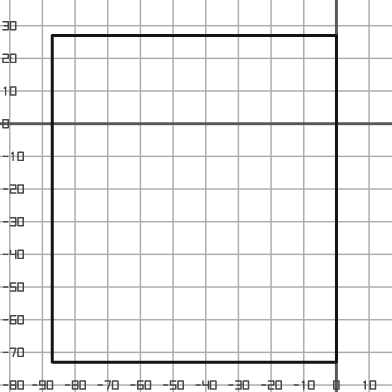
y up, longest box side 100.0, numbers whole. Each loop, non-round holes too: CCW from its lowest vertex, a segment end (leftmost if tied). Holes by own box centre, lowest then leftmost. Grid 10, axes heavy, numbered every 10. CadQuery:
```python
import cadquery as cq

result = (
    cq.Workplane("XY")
    .moveTo(-87.0, -73.0)
    .lineTo(0.0, -73.0)
    .lineTo(0.0, 27.0)
    .lineTo(-87.0, 27.0)
    .close()
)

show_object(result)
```